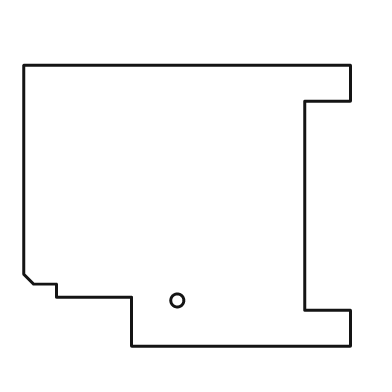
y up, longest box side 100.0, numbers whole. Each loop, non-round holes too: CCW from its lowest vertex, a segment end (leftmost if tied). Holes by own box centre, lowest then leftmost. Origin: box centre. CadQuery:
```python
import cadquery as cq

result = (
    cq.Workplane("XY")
    .moveTo(-17.0, -43.0)
    .lineTo(50.0, -43.0)
    .lineTo(50.0, -32.0)
    .lineTo(36.0, -32.0)
    .lineTo(36.0, 32.0)
    .lineTo(50.0, 32.0)
    .lineTo(50.0, 43.0)
    .lineTo(-50.0, 43.0)
    .lineTo(-50.0, -21.0)
    .lineTo(-47.0, -24.0)
    .lineTo(-40.0, -24.0)
    .lineTo(-40.0, -28.0)
    .lineTo(-17.0, -28.0)
    .close()
    .moveTo(-3.0, -29.0)
    .circle(2.0)
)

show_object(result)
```